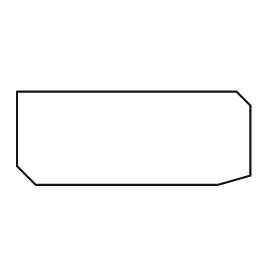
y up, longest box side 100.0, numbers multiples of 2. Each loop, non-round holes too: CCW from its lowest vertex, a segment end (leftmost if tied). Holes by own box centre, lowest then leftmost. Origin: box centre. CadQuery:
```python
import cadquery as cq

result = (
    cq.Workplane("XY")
    .moveTo(-42.0, -20.0)
    .lineTo(36.0, -20.0)
    .lineTo(50.0, -16.0)
    .lineTo(50.0, 14.0)
    .lineTo(44.0, 20.0)
    .lineTo(-50.0, 20.0)
    .lineTo(-50.0, -12.0)
    .close()
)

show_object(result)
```